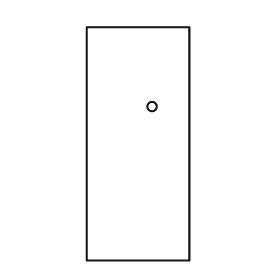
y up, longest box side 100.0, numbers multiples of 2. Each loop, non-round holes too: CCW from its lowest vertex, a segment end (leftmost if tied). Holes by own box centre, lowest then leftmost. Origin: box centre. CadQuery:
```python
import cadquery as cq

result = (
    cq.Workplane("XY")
    .moveTo(-22.0, -50.0)
    .lineTo(22.0, -50.0)
    .lineTo(22.0, 50.0)
    .lineTo(-22.0, 50.0)
    .close()
    .moveTo(6.0, 16.0)
    .circle(2.0)
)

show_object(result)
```